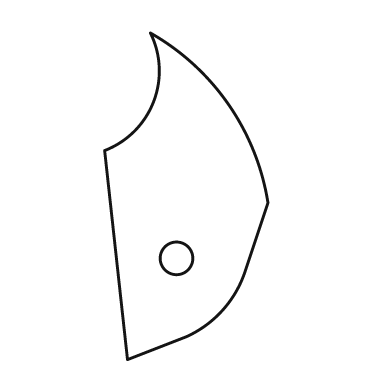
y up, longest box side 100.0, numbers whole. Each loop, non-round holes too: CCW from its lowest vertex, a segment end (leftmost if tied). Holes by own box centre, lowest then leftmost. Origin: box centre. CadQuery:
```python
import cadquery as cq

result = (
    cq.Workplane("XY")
    .moveTo(-18.0, -50.0)
    .lineTo(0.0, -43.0)
    .threePointArc((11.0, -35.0), (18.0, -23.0))
    .lineTo(25.0, -2.0)
    .threePointArc((13.0, 28.0), (-11.0, 50.0))
    .threePointArc((-10.0, 29.0), (-25.0, 14.0))
    .close()
    .moveTo(-3.0, -19.0)
    .circle(5.0)
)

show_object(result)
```